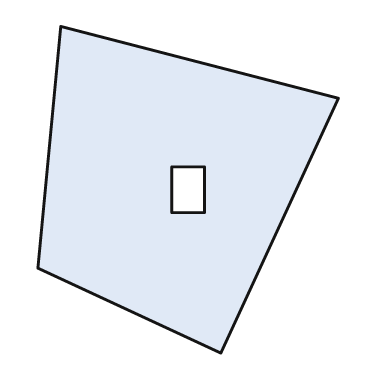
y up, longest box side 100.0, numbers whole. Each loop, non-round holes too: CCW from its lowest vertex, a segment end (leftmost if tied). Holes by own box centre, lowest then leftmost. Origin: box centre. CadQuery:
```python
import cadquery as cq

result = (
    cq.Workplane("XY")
    .moveTo(10.0, -50.0)
    .lineTo(46.0, 28.0)
    .lineTo(-39.0, 50.0)
    .lineTo(-46.0, -24.0)
    .close()
    .moveTo(-5.0, -7.0)
    .lineTo(5.0, -7.0)
    .lineTo(5.0, 7.0)
    .lineTo(-5.0, 7.0)
    .close()
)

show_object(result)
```